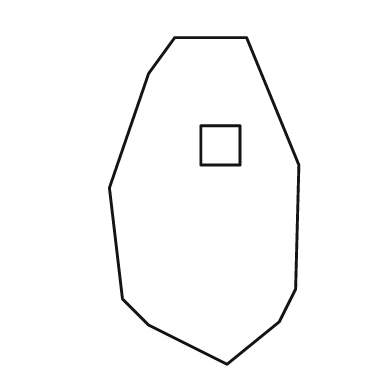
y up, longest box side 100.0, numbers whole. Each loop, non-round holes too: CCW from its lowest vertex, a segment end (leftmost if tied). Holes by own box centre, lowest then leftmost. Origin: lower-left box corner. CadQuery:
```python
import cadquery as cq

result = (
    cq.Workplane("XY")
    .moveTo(36.0, 0.0)
    .lineTo(52.0, 13.0)
    .lineTo(57.0, 23.0)
    .lineTo(58.0, 61.0)
    .lineTo(42.0, 100.0)
    .lineTo(20.0, 100.0)
    .lineTo(12.0, 89.0)
    .lineTo(0.0, 54.0)
    .lineTo(4.0, 20.0)
    .lineTo(12.0, 12.0)
    .close()
    .moveTo(28.0, 61.0)
    .lineTo(40.0, 61.0)
    .lineTo(40.0, 73.0)
    .lineTo(28.0, 73.0)
    .close()
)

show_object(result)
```